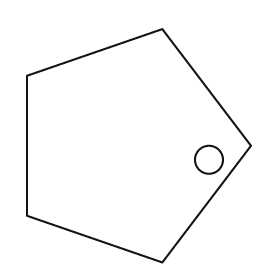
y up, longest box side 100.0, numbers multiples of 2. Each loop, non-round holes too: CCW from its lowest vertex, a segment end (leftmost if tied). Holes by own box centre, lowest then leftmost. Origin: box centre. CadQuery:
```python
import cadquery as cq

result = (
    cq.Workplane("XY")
    .moveTo(10.0, -50.0)
    .lineTo(48.0, 0.0)
    .lineTo(10.0, 50.0)
    .lineTo(-48.0, 30.0)
    .lineTo(-48.0, -30.0)
    .close()
    .moveTo(30.0, -6.0)
    .circle(6.0)
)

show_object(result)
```